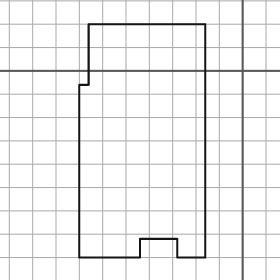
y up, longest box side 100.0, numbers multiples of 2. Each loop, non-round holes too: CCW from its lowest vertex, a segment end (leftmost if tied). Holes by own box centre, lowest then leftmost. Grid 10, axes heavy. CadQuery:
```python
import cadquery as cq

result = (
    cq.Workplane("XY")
    .moveTo(-70.0, -80.0)
    .lineTo(-44.0, -80.0)
    .lineTo(-44.0, -72.0)
    .lineTo(-28.0, -72.0)
    .lineTo(-28.0, -80.0)
    .lineTo(-16.0, -80.0)
    .lineTo(-16.0, 20.0)
    .lineTo(-66.0, 20.0)
    .lineTo(-66.0, -6.0)
    .lineTo(-70.0, -6.0)
    .close()
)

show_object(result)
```